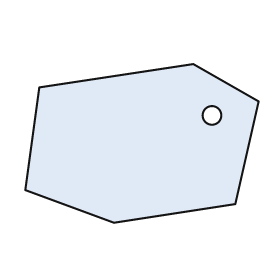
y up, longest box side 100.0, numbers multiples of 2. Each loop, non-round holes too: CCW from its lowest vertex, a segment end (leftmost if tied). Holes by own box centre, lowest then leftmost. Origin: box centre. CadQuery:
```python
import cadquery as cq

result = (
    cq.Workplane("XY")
    .moveTo(-12.0, -34.0)
    .lineTo(40.0, -26.0)
    .lineTo(50.0, 18.0)
    .lineTo(22.0, 34.0)
    .lineTo(-44.0, 24.0)
    .lineTo(-50.0, -20.0)
    .close()
    .moveTo(30.0, 12.0)
    .circle(4.0)
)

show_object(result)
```